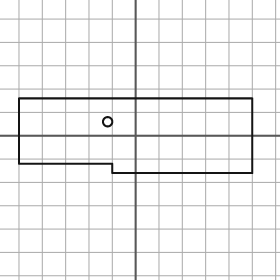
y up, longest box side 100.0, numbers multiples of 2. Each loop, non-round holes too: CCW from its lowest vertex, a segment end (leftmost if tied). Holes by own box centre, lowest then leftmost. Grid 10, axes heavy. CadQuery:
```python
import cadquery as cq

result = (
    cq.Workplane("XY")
    .moveTo(-10.0, -16.0)
    .lineTo(50.0, -16.0)
    .lineTo(50.0, 16.0)
    .lineTo(-50.0, 16.0)
    .lineTo(-50.0, -12.0)
    .lineTo(-10.0, -12.0)
    .close()
    .moveTo(-12.0, 6.0)
    .circle(2.0)
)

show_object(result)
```